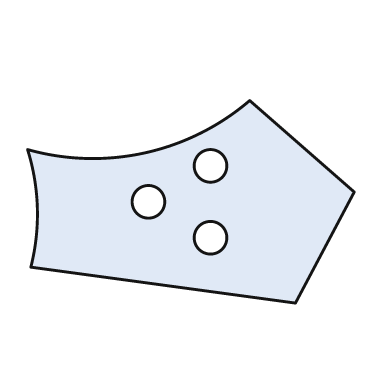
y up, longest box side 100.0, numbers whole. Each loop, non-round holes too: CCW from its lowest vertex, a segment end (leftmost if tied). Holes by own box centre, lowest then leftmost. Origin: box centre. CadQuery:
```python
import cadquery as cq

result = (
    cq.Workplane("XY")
    .moveTo(32.0, -31.0)
    .lineTo(50.0, 3.0)
    .lineTo(18.0, 31.0)
    .threePointArc((-14.0, 15.0), (-50.0, 16.0))
    .threePointArc((-47.0, -2.0), (-49.0, -20.0))
    .close()
    .moveTo(6.0, -11.0)
    .circle(5.0)
    .moveTo(-13.0, 0.0)
    .circle(5.0)
    .moveTo(6.0, 11.0)
    .circle(5.0)
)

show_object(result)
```